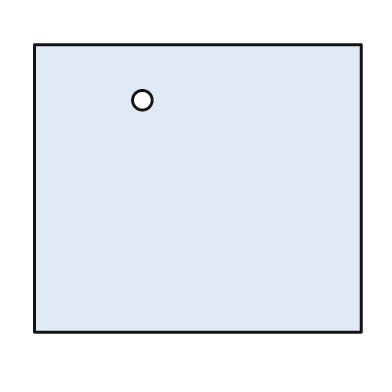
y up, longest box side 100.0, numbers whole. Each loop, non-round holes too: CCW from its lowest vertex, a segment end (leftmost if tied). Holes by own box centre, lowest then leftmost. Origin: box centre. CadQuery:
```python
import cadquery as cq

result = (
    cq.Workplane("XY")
    .moveTo(-50.0, -44.0)
    .lineTo(50.0, -44.0)
    .lineTo(50.0, 44.0)
    .lineTo(-50.0, 44.0)
    .close()
    .moveTo(-17.0, 27.0)
    .circle(3.0)
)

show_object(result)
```